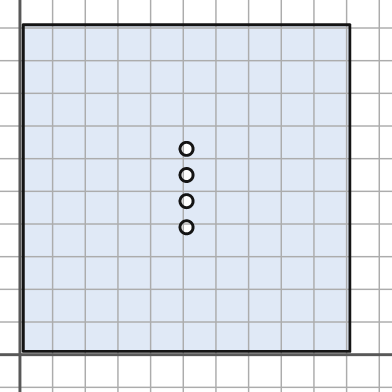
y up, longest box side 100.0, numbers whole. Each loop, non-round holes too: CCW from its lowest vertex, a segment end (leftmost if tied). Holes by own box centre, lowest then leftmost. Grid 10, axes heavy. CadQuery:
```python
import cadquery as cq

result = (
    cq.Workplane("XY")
    .moveTo(1.0, 1.0)
    .lineTo(101.0, 1.0)
    .lineTo(101.0, 101.0)
    .lineTo(1.0, 101.0)
    .close()
    .moveTo(51.0, 39.0)
    .circle(2.0)
    .moveTo(51.0, 47.0)
    .circle(2.0)
    .moveTo(51.0, 55.0)
    .circle(2.0)
    .moveTo(51.0, 63.0)
    .circle(2.0)
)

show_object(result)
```